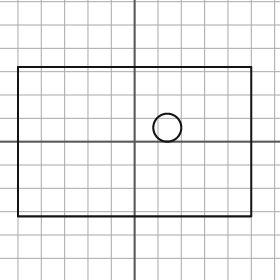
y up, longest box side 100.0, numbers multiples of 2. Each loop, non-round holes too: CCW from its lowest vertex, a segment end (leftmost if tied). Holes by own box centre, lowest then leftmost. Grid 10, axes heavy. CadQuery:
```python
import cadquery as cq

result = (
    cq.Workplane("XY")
    .moveTo(-50.0, -32.0)
    .lineTo(50.0, -32.0)
    .lineTo(50.0, 32.0)
    .lineTo(-50.0, 32.0)
    .close()
    .moveTo(14.0, 6.0)
    .circle(6.0)
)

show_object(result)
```